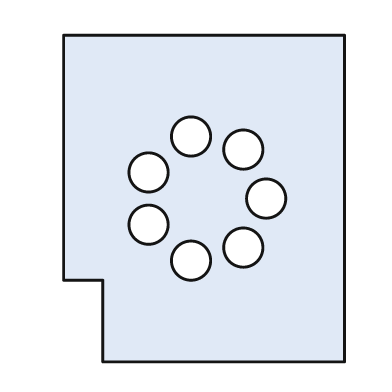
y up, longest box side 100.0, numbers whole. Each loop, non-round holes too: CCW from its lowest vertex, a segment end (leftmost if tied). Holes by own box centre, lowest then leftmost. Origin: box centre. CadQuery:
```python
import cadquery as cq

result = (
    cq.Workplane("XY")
    .moveTo(-31.0, -50.0)
    .lineTo(43.0, -50.0)
    .lineTo(43.0, 50.0)
    .lineTo(-43.0, 50.0)
    .lineTo(-43.0, -25.0)
    .lineTo(-31.0, -25.0)
    .close()
    .moveTo(-4.0, -19.0)
    .circle(6.0)
    .moveTo(12.0, -15.0)
    .circle(6.0)
    .moveTo(-17.0, -8.0)
    .circle(6.0)
    .moveTo(19.0, 0.0)
    .circle(6.0)
    .moveTo(-17.0, 8.0)
    .circle(6.0)
    .moveTo(12.0, 15.0)
    .circle(6.0)
    .moveTo(-4.0, 19.0)
    .circle(6.0)
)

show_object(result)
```